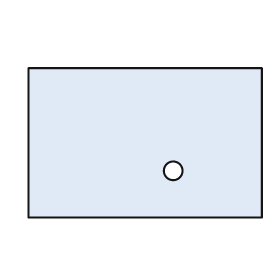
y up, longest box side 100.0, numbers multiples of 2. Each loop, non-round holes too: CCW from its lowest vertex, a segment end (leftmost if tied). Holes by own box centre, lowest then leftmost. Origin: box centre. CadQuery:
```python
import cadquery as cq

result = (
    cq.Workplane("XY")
    .moveTo(-50.0, -32.0)
    .lineTo(50.0, -32.0)
    .lineTo(50.0, 32.0)
    .lineTo(-50.0, 32.0)
    .close()
    .moveTo(12.0, -12.0)
    .circle(4.0)
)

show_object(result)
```